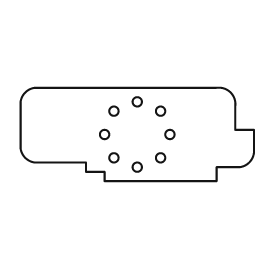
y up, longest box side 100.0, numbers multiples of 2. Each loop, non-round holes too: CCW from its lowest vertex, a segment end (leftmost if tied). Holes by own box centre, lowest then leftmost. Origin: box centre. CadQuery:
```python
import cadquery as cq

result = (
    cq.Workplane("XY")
    .moveTo(-14.0, -20.0)
    .lineTo(34.0, -20.0)
    .lineTo(34.0, -14.0)
    .lineTo(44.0, -14.0)
    .threePointArc((48.0, -12.0), (50.0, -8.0))
    .lineTo(50.0, 2.0)
    .lineTo(42.0, 2.0)
    .lineTo(42.0, 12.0)
    .threePointArc((40.0, 18.0), (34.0, 20.0))
    .lineTo(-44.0, 20.0)
    .threePointArc((-48.0, 18.0), (-50.0, 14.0))
    .lineTo(-50.0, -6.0)
    .threePointArc((-48.0, -10.0), (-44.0, -12.0))
    .lineTo(-22.0, -12.0)
    .lineTo(-22.0, -16.0)
    .lineTo(-14.0, -16.0)
    .close()
    .moveTo(0.0, -14.0)
    .circle(2.0)
    .moveTo(-10.0, -10.0)
    .circle(2.0)
    .moveTo(10.0, -10.0)
    .circle(2.0)
    .moveTo(-14.0, 0.0)
    .circle(2.0)
    .moveTo(14.0, 0.0)
    .circle(2.0)
    .moveTo(-10.0, 10.0)
    .circle(2.0)
    .moveTo(10.0, 10.0)
    .circle(2.0)
    .moveTo(0.0, 14.0)
    .circle(2.0)
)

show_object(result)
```